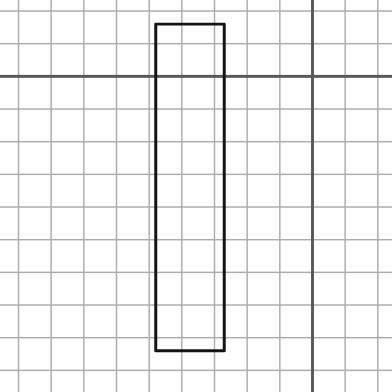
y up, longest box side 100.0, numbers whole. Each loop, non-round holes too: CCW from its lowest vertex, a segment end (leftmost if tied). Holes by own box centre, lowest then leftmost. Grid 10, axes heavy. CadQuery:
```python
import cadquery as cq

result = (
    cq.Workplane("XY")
    .moveTo(-48.0, -84.0)
    .lineTo(-27.0, -84.0)
    .lineTo(-27.0, 16.0)
    .lineTo(-48.0, 16.0)
    .close()
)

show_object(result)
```